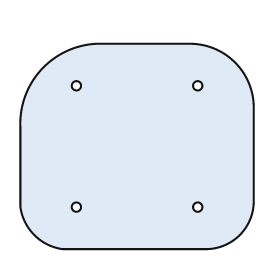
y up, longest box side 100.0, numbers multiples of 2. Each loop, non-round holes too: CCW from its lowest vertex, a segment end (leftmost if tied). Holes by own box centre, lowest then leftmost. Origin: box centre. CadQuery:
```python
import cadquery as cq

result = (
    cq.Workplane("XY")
    .moveTo(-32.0, -44.0)
    .lineTo(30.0, -44.0)
    .threePointArc((44.0, -38.0), (50.0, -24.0))
    .lineTo(50.0, 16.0)
    .threePointArc((42.0, 36.0), (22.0, 44.0))
    .lineTo(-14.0, 44.0)
    .threePointArc((-40.0, 34.0), (-50.0, 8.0))
    .lineTo(-50.0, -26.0)
    .threePointArc((-44.0, -38.0), (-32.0, -44.0))
    .close()
    .moveTo(-26.0, -26.0)
    .circle(2.0)
    .moveTo(26.0, -26.0)
    .circle(2.0)
    .moveTo(-26.0, 26.0)
    .circle(2.0)
    .moveTo(26.0, 26.0)
    .circle(2.0)
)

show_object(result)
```